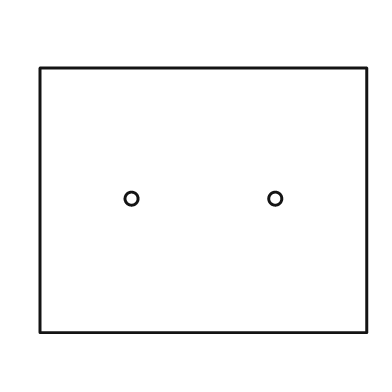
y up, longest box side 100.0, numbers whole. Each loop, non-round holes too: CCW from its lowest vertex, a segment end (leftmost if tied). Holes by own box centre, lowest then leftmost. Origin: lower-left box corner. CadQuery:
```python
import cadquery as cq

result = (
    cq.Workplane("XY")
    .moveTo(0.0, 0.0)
    .lineTo(100.0, 0.0)
    .lineTo(100.0, 81.0)
    .lineTo(0.0, 81.0)
    .close()
    .moveTo(28.0, 41.0)
    .circle(2.0)
    .moveTo(72.0, 41.0)
    .circle(2.0)
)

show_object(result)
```